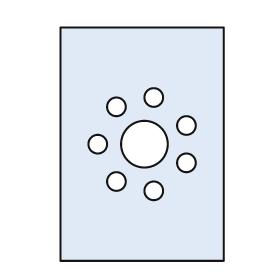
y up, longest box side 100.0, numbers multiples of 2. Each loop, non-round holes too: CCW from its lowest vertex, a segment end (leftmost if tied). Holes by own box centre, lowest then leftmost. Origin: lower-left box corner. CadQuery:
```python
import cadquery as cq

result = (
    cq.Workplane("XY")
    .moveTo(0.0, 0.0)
    .lineTo(70.0, 0.0)
    .lineTo(70.0, 100.0)
    .lineTo(0.0, 100.0)
    .close()
    .moveTo(40.0, 30.0)
    .circle(4.0)
    .moveTo(24.0, 34.0)
    .circle(4.0)
    .moveTo(54.0, 42.0)
    .circle(4.0)
    .moveTo(16.0, 50.0)
    .circle(4.0)
    .moveTo(36.0, 50.0)
    .circle(10.0)
    .moveTo(54.0, 58.0)
    .circle(4.0)
    .moveTo(24.0, 66.0)
    .circle(4.0)
    .moveTo(40.0, 70.0)
    .circle(4.0)
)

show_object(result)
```